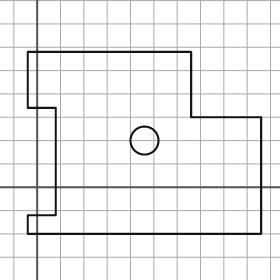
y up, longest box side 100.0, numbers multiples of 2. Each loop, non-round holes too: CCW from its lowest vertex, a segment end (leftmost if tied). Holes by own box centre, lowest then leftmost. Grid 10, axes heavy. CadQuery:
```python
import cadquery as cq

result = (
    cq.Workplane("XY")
    .moveTo(-4.0, -20.0)
    .lineTo(96.0, -20.0)
    .lineTo(96.0, 30.0)
    .lineTo(66.0, 30.0)
    .lineTo(66.0, 58.0)
    .lineTo(-4.0, 58.0)
    .lineTo(-4.0, 34.0)
    .lineTo(8.0, 34.0)
    .lineTo(8.0, -12.0)
    .lineTo(-4.0, -12.0)
    .close()
    .moveTo(46.0, 20.0)
    .circle(6.0)
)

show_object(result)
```